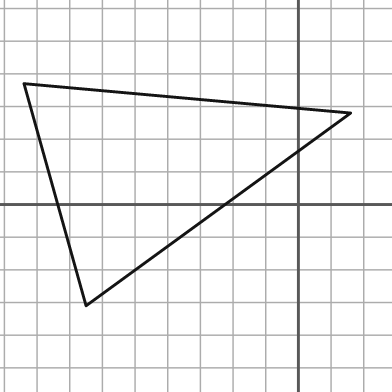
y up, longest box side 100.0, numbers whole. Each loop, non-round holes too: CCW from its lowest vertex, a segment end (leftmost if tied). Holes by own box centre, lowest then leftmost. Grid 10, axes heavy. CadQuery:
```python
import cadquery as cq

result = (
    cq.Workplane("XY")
    .moveTo(-65.0, -31.0)
    .lineTo(16.0, 28.0)
    .lineTo(-84.0, 37.0)
    .close()
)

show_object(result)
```